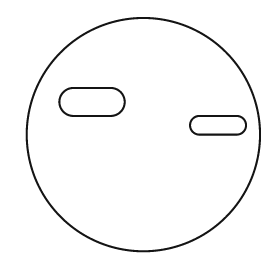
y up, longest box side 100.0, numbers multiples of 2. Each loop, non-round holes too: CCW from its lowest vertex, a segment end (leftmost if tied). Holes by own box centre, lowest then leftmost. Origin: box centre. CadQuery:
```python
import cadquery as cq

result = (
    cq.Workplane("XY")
    .moveTo(0.0, 0.0)
    .circle(50.0)
    .moveTo(24.0, 0.0)
    .lineTo(40.0, 0.0)
    .threePointArc((44.0, 4.0), (40.0, 8.0))
    .lineTo(24.0, 8.0)
    .threePointArc((20.0, 4.0), (24.0, 0.0))
    .close()
    .moveTo(-30.0, 8.0)
    .lineTo(-14.0, 8.0)
    .threePointArc((-8.0, 14.0), (-14.0, 20.0))
    .lineTo(-30.0, 20.0)
    .threePointArc((-36.0, 14.0), (-30.0, 8.0))
    .close()
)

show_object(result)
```